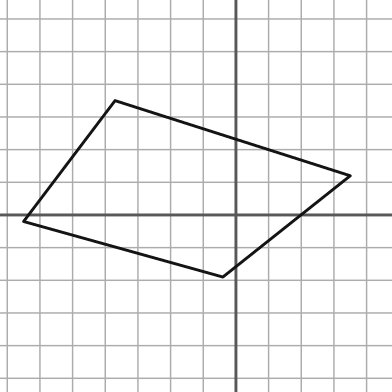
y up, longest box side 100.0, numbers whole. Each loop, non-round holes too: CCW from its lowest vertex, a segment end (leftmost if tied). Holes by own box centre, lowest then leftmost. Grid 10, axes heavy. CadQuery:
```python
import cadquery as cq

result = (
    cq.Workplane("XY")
    .moveTo(-4.0, -19.0)
    .lineTo(35.0, 12.0)
    .lineTo(-37.0, 35.0)
    .lineTo(-65.0, -2.0)
    .close()
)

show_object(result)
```